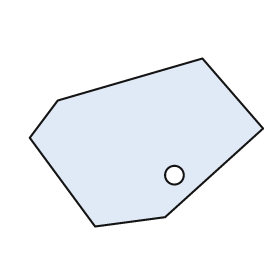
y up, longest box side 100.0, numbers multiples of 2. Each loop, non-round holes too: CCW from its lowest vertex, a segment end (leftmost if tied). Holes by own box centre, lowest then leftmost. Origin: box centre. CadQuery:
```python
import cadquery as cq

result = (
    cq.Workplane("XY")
    .moveTo(-22.0, -36.0)
    .lineTo(8.0, -32.0)
    .lineTo(50.0, 6.0)
    .lineTo(24.0, 36.0)
    .lineTo(-38.0, 18.0)
    .lineTo(-50.0, 2.0)
    .close()
    .moveTo(12.0, -14.0)
    .circle(4.0)
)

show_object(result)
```